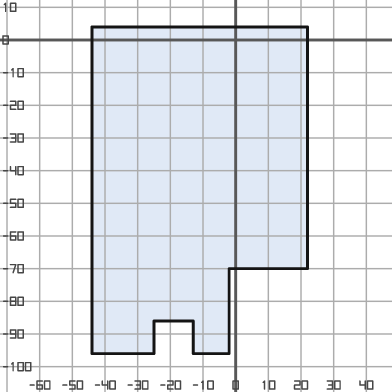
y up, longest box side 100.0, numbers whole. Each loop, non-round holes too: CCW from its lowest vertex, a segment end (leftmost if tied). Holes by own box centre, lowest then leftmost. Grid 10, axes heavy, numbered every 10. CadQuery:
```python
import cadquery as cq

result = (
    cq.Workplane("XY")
    .moveTo(-44.0, -96.0)
    .lineTo(-25.0, -96.0)
    .lineTo(-25.0, -86.0)
    .lineTo(-13.0, -86.0)
    .lineTo(-13.0, -96.0)
    .lineTo(-2.0, -96.0)
    .lineTo(-2.0, -70.0)
    .lineTo(22.0, -70.0)
    .lineTo(22.0, 4.0)
    .lineTo(-44.0, 4.0)
    .close()
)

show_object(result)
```